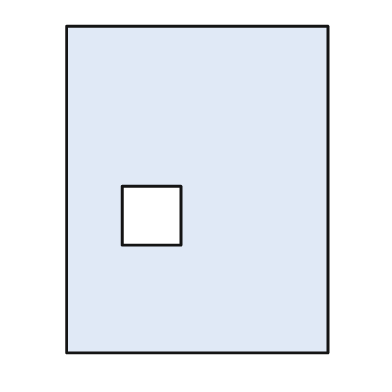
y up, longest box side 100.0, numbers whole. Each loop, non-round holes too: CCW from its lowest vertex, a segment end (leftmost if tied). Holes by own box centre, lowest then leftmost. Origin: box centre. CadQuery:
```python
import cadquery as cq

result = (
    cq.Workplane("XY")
    .moveTo(-40.0, -50.0)
    .lineTo(40.0, -50.0)
    .lineTo(40.0, 50.0)
    .lineTo(-40.0, 50.0)
    .close()
    .moveTo(-23.0, -17.0)
    .lineTo(-5.0, -17.0)
    .lineTo(-5.0, 1.0)
    .lineTo(-23.0, 1.0)
    .close()
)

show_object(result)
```